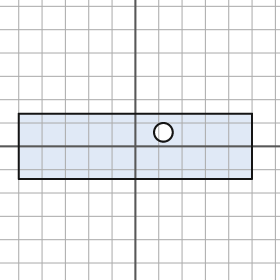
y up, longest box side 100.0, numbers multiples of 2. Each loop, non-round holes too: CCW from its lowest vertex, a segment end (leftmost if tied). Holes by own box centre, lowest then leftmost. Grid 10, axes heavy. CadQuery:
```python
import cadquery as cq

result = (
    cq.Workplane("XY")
    .moveTo(-50.0, -14.0)
    .lineTo(50.0, -14.0)
    .lineTo(50.0, 14.0)
    .lineTo(-50.0, 14.0)
    .close()
    .moveTo(12.0, 6.0)
    .circle(4.0)
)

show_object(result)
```